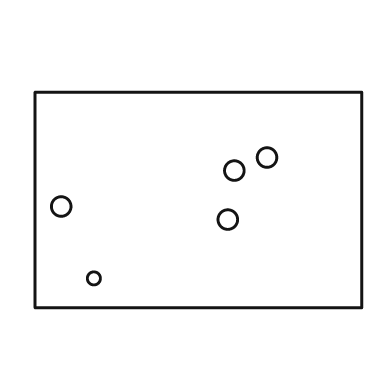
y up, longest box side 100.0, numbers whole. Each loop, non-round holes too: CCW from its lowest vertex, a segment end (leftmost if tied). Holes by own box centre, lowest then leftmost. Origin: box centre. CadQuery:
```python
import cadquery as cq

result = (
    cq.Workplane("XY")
    .moveTo(-50.0, -33.0)
    .lineTo(50.0, -33.0)
    .lineTo(50.0, 33.0)
    .lineTo(-50.0, 33.0)
    .close()
    .moveTo(-32.0, -24.0)
    .circle(2.0)
    .moveTo(9.0, -6.0)
    .circle(3.0)
    .moveTo(-42.0, -2.0)
    .circle(3.0)
    .moveTo(11.0, 9.0)
    .circle(3.0)
    .moveTo(21.0, 13.0)
    .circle(3.0)
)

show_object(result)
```